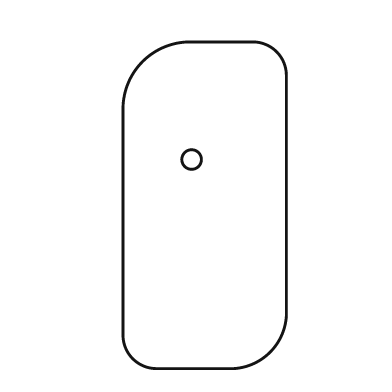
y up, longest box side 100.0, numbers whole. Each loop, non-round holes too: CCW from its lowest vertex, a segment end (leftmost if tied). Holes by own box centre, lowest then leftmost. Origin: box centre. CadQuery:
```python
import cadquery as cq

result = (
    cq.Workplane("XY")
    .moveTo(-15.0, -50.0)
    .lineTo(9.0, -50.0)
    .threePointArc((20.0, -45.0), (25.0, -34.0))
    .lineTo(25.0, 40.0)
    .threePointArc((22.0, 47.0), (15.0, 50.0))
    .lineTo(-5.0, 50.0)
    .threePointArc((-19.0, 44.0), (-25.0, 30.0))
    .lineTo(-25.0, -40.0)
    .threePointArc((-22.0, -47.0), (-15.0, -50.0))
    .close()
    .moveTo(-4.0, 14.0)
    .circle(3.0)
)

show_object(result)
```